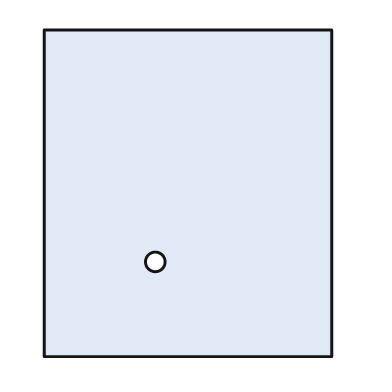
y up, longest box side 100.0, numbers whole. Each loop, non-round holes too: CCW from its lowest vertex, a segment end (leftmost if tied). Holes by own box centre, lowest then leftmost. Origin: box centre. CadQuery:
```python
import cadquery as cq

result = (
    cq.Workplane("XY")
    .moveTo(-44.0, -50.0)
    .lineTo(44.0, -50.0)
    .lineTo(44.0, 50.0)
    .lineTo(-44.0, 50.0)
    .close()
    .moveTo(-10.0, -21.0)
    .circle(3.0)
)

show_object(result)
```